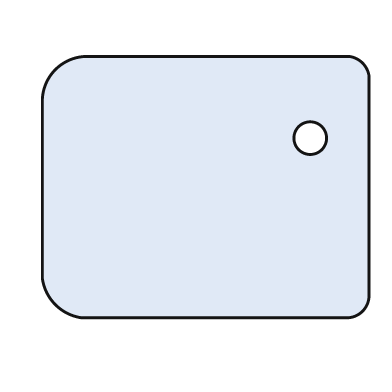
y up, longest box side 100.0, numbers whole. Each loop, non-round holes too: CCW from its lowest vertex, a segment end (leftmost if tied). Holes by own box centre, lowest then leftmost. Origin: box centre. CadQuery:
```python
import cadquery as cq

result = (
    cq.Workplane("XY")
    .moveTo(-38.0, -40.0)
    .lineTo(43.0, -40.0)
    .threePointArc((48.0, -38.0), (50.0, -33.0))
    .lineTo(50.0, 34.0)
    .threePointArc((48.0, 38.0), (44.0, 40.0))
    .lineTo(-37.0, 40.0)
    .threePointArc((-46.0, 36.0), (-50.0, 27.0))
    .lineTo(-50.0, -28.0)
    .threePointArc((-46.0, -36.0), (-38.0, -40.0))
    .close()
    .moveTo(32.0, 15.0)
    .circle(5.0)
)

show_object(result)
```